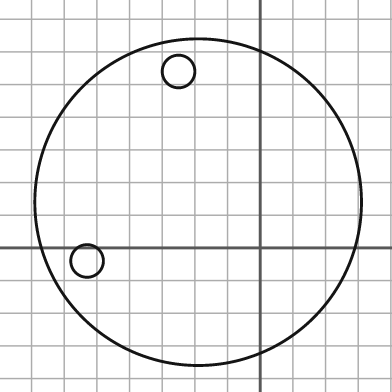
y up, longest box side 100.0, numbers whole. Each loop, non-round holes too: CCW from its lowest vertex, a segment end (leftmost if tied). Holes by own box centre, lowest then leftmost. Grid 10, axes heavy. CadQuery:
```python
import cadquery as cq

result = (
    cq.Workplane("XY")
    .moveTo(-19.0, 14.0)
    .circle(50.0)
    .moveTo(-53.0, -4.0)
    .circle(5.0)
    .moveTo(-25.0, 54.0)
    .circle(5.0)
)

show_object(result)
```